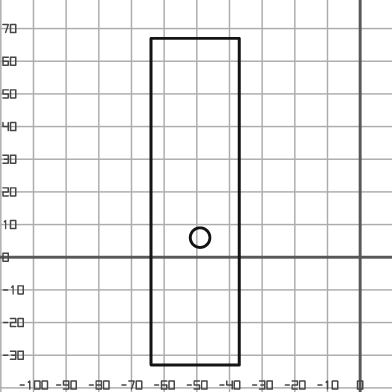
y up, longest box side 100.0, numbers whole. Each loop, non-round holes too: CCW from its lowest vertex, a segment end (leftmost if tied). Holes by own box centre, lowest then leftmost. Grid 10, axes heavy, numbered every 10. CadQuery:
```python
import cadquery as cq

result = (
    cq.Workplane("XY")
    .moveTo(-64.0, -33.0)
    .lineTo(-37.0, -33.0)
    .lineTo(-37.0, 67.0)
    .lineTo(-64.0, 67.0)
    .close()
    .moveTo(-49.0, 6.0)
    .circle(3.0)
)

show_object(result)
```